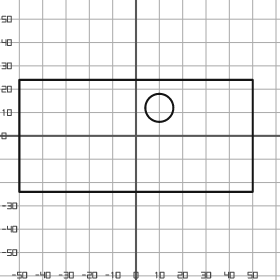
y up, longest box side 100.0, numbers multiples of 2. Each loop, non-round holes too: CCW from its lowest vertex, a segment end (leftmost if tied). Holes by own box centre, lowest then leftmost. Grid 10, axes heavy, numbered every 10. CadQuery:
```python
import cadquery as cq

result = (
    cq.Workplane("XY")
    .moveTo(-50.0, -24.0)
    .lineTo(50.0, -24.0)
    .lineTo(50.0, 24.0)
    .lineTo(-50.0, 24.0)
    .close()
    .moveTo(10.0, 12.0)
    .circle(6.0)
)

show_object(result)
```